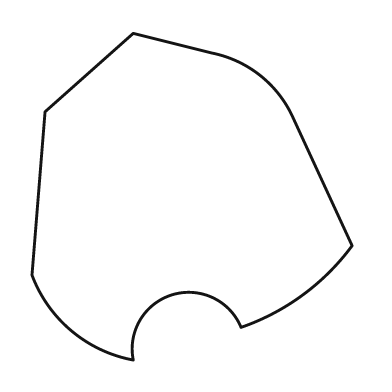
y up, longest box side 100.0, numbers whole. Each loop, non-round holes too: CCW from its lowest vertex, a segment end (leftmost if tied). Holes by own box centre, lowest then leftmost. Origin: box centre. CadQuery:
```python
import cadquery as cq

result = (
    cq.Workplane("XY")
    .moveTo(-18.0, -50.0)
    .threePointArc((-6.0, -30.0), (15.0, -40.0))
    .threePointArc((34.0, -30.0), (49.0, -15.0))
    .lineTo(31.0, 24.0)
    .threePointArc((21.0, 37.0), (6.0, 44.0))
    .lineTo(-18.0, 50.0)
    .lineTo(-45.0, 26.0)
    .lineTo(-49.0, -24.0)
    .threePointArc((-37.0, -41.0), (-18.0, -50.0))
    .close()
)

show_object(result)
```